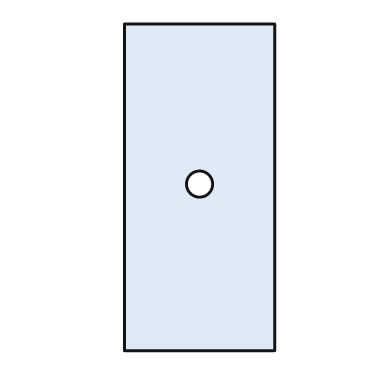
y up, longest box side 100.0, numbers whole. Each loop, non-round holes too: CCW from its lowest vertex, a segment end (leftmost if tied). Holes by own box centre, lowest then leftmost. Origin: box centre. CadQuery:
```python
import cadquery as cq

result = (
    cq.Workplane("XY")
    .moveTo(-23.0, -50.0)
    .lineTo(23.0, -50.0)
    .lineTo(23.0, 50.0)
    .lineTo(-23.0, 50.0)
    .close()
    .moveTo(0.0, 1.0)
    .circle(4.0)
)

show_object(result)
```